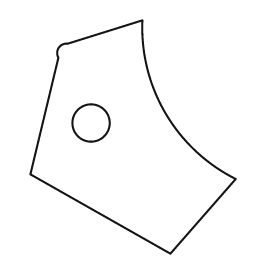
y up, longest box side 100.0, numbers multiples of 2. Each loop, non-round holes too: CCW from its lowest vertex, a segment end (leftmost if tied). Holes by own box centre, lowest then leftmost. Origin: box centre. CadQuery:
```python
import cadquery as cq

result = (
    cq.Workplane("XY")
    .moveTo(16.0, -50.0)
    .lineTo(44.0, -18.0)
    .threePointArc((14.0, 10.0), (4.0, 50.0))
    .lineTo(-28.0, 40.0)
    .threePointArc((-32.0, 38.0), (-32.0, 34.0))
    .lineTo(-44.0, -16.0)
    .close()
    .moveTo(-18.0, 6.0)
    .circle(8.0)
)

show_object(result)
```